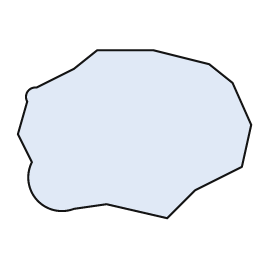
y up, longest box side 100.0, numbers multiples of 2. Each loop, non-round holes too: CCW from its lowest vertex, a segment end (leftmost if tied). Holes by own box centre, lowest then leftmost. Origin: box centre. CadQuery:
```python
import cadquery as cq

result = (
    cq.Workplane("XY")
    .moveTo(14.0, -36.0)
    .lineTo(26.0, -24.0)
    .lineTo(46.0, -14.0)
    .lineTo(50.0, 4.0)
    .lineTo(42.0, 22.0)
    .lineTo(32.0, 30.0)
    .lineTo(8.0, 36.0)
    .lineTo(-16.0, 36.0)
    .lineTo(-26.0, 28.0)
    .lineTo(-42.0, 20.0)
    .threePointArc((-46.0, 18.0), (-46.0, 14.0))
    .lineTo(-50.0, 0.0)
    .lineTo(-44.0, -12.0)
    .threePointArc((-42.0, -28.0), (-26.0, -32.0))
    .lineTo(-12.0, -30.0)
    .close()
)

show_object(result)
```